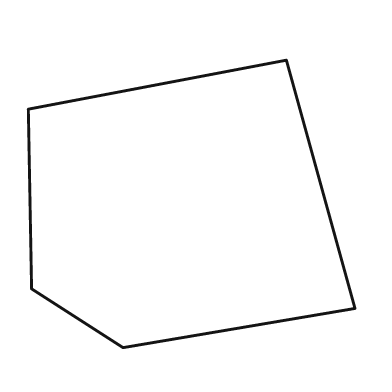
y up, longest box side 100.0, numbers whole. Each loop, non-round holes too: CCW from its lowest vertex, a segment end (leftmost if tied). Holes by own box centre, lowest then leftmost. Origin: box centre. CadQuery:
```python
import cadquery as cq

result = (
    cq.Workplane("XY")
    .moveTo(-21.0, -44.0)
    .lineTo(50.0, -32.0)
    .lineTo(29.0, 44.0)
    .lineTo(-50.0, 29.0)
    .lineTo(-49.0, -26.0)
    .close()
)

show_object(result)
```